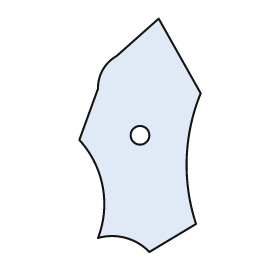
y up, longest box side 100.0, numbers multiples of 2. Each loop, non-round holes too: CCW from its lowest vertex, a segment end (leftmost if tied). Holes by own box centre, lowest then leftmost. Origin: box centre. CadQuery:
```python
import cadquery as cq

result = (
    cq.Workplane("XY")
    .moveTo(4.0, -50.0)
    .lineTo(24.0, -38.0)
    .threePointArc((20.0, -10.0), (26.0, 18.0))
    .lineTo(8.0, 50.0)
    .lineTo(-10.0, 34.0)
    .threePointArc((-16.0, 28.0), (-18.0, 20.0))
    .lineTo(-26.0, -2.0)
    .threePointArc((-16.0, -22.0), (-18.0, -44.0))
    .threePointArc((-6.0, -44.0), (4.0, -50.0))
    .close()
    .moveTo(0.0, 0.0)
    .circle(4.0)
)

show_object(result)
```